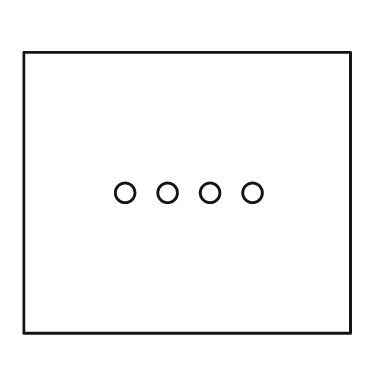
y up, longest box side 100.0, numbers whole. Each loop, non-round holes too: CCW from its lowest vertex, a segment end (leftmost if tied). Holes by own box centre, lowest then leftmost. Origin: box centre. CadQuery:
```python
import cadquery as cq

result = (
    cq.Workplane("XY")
    .moveTo(-50.0, -43.0)
    .lineTo(50.0, -43.0)
    .lineTo(50.0, 43.0)
    .lineTo(-50.0, 43.0)
    .close()
    .moveTo(-19.0, 0.0)
    .circle(3.0)
    .moveTo(-6.0, 0.0)
    .circle(3.0)
    .moveTo(7.0, 0.0)
    .circle(3.0)
    .moveTo(20.0, 0.0)
    .circle(3.0)
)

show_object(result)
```